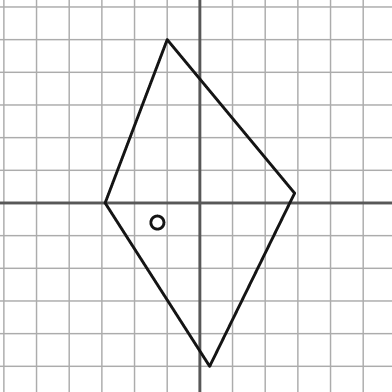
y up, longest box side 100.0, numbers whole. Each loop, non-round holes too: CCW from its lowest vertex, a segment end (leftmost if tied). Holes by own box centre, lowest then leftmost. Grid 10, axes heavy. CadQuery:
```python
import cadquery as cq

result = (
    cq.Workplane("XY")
    .moveTo(3.0, -50.0)
    .lineTo(29.0, 3.0)
    .lineTo(-10.0, 50.0)
    .lineTo(-29.0, 0.0)
    .close()
    .moveTo(-13.0, -6.0)
    .circle(2.0)
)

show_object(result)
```